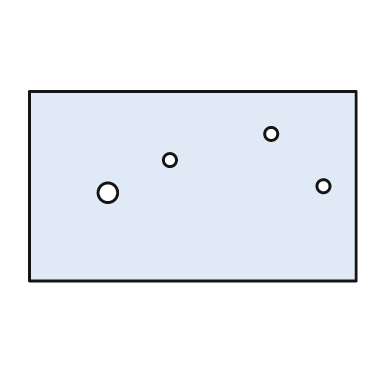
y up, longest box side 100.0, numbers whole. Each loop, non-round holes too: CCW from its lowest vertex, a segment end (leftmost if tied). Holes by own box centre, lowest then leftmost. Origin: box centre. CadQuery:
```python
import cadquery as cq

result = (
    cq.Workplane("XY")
    .moveTo(-50.0, -29.0)
    .lineTo(50.0, -29.0)
    .lineTo(50.0, 29.0)
    .lineTo(-50.0, 29.0)
    .close()
    .moveTo(-26.0, -2.0)
    .circle(3.0)
    .moveTo(40.0, 0.0)
    .circle(2.0)
    .moveTo(-7.0, 8.0)
    .circle(2.0)
    .moveTo(24.0, 16.0)
    .circle(2.0)
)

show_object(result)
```